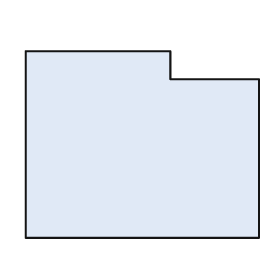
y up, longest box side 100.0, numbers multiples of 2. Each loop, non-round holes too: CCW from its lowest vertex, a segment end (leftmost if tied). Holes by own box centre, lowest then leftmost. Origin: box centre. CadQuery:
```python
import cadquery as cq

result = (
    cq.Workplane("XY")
    .moveTo(-50.0, -40.0)
    .lineTo(50.0, -40.0)
    .lineTo(50.0, 28.0)
    .lineTo(12.0, 28.0)
    .lineTo(12.0, 40.0)
    .lineTo(-50.0, 40.0)
    .close()
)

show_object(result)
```